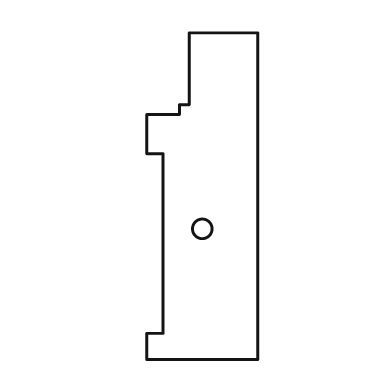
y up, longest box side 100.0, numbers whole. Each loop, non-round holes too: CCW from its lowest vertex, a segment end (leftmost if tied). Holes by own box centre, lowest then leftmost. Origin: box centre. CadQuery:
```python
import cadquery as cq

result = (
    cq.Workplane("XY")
    .moveTo(-17.0, -50.0)
    .lineTo(17.0, -50.0)
    .lineTo(17.0, 50.0)
    .lineTo(-4.0, 50.0)
    .lineTo(-4.0, 28.0)
    .lineTo(-7.0, 28.0)
    .lineTo(-7.0, 25.0)
    .lineTo(-17.0, 25.0)
    .lineTo(-17.0, 13.0)
    .lineTo(-12.0, 13.0)
    .lineTo(-12.0, -42.0)
    .lineTo(-17.0, -42.0)
    .close()
    .moveTo(0.0, -10.0)
    .circle(3.0)
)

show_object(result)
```